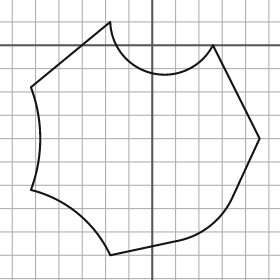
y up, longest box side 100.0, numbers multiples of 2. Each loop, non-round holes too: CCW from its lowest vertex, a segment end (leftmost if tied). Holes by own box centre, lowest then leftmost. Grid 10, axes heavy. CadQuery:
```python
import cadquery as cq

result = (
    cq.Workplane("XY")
    .moveTo(-18.0, -90.0)
    .lineTo(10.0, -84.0)
    .threePointArc((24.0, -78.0), (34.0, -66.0))
    .lineTo(46.0, -40.0)
    .lineTo(26.0, 0.0)
    .threePointArc((0.0, -12.0), (-18.0, 10.0))
    .lineTo(-52.0, -18.0)
    .threePointArc((-48.0, -40.0), (-52.0, -62.0))
    .threePointArc((-32.0, -72.0), (-18.0, -90.0))
    .close()
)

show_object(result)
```